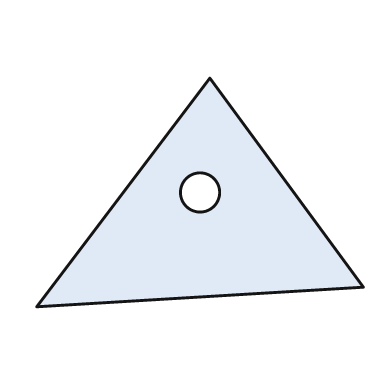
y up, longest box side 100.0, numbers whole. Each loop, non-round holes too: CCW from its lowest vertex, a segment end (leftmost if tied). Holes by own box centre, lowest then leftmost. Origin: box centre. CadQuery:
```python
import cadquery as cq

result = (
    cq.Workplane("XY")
    .moveTo(-50.0, -35.0)
    .lineTo(50.0, -29.0)
    .lineTo(3.0, 35.0)
    .close()
    .moveTo(0.0, 0.0)
    .circle(6.0)
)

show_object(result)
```